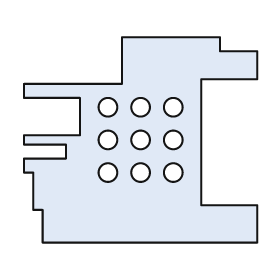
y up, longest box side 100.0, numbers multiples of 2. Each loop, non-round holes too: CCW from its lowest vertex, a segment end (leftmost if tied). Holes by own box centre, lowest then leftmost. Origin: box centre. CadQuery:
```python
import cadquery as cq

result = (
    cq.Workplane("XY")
    .moveTo(-42.0, -44.0)
    .lineTo(50.0, -44.0)
    .lineTo(50.0, -28.0)
    .lineTo(26.0, -28.0)
    .lineTo(26.0, 26.0)
    .lineTo(50.0, 26.0)
    .lineTo(50.0, 38.0)
    .lineTo(34.0, 38.0)
    .lineTo(34.0, 44.0)
    .lineTo(-8.0, 44.0)
    .lineTo(-8.0, 24.0)
    .lineTo(-50.0, 24.0)
    .lineTo(-50.0, 18.0)
    .lineTo(-26.0, 18.0)
    .lineTo(-26.0, 2.0)
    .lineTo(-50.0, 2.0)
    .lineTo(-50.0, -2.0)
    .lineTo(-32.0, -2.0)
    .lineTo(-32.0, -8.0)
    .lineTo(-50.0, -8.0)
    .lineTo(-50.0, -14.0)
    .lineTo(-46.0, -14.0)
    .lineTo(-46.0, -30.0)
    .lineTo(-42.0, -30.0)
    .close()
    .moveTo(-14.0, -14.0)
    .circle(4.0)
    .moveTo(0.0, -14.0)
    .circle(4.0)
    .moveTo(14.0, -14.0)
    .circle(4.0)
    .moveTo(-14.0, 0.0)
    .circle(4.0)
    .moveTo(0.0, 0.0)
    .circle(4.0)
    .moveTo(14.0, 0.0)
    .circle(4.0)
    .moveTo(-14.0, 14.0)
    .circle(4.0)
    .moveTo(0.0, 14.0)
    .circle(4.0)
    .moveTo(14.0, 14.0)
    .circle(4.0)
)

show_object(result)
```